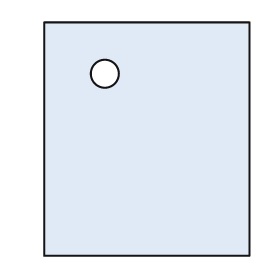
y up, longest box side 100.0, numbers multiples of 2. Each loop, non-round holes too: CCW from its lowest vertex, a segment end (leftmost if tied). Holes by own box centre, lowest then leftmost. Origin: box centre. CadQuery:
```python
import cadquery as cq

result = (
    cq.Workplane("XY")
    .moveTo(-44.0, -50.0)
    .lineTo(44.0, -50.0)
    .lineTo(44.0, 50.0)
    .lineTo(-44.0, 50.0)
    .close()
    .moveTo(-18.0, 28.0)
    .circle(6.0)
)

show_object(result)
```